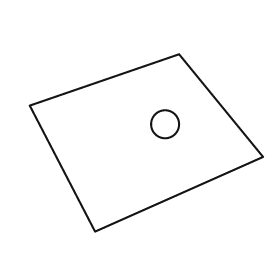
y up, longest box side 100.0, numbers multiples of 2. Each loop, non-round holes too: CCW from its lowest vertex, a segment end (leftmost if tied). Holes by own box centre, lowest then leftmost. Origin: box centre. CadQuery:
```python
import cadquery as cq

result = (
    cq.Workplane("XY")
    .moveTo(-22.0, -38.0)
    .lineTo(50.0, -6.0)
    .lineTo(14.0, 38.0)
    .lineTo(-50.0, 16.0)
    .close()
    .moveTo(8.0, 8.0)
    .circle(6.0)
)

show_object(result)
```